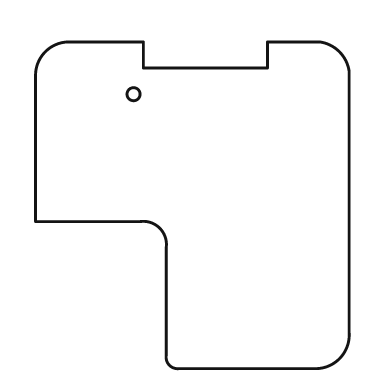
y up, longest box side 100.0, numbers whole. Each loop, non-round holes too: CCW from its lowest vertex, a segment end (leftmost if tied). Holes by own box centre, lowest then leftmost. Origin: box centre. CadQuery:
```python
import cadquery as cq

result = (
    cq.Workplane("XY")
    .moveTo(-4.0, -50.0)
    .lineTo(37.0, -50.0)
    .threePointArc((45.0, -47.0), (48.0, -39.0))
    .lineTo(48.0, 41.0)
    .threePointArc((45.0, 47.0), (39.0, 50.0))
    .lineTo(23.0, 50.0)
    .lineTo(23.0, 42.0)
    .lineTo(-15.0, 42.0)
    .lineTo(-15.0, 50.0)
    .lineTo(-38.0, 50.0)
    .threePointArc((-45.0, 47.0), (-48.0, 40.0))
    .lineTo(-48.0, -5.0)
    .lineTo(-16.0, -5.0)
    .threePointArc((-10.0, -7.0), (-8.0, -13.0))
    .lineTo(-8.0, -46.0)
    .threePointArc((-7.0, -49.0), (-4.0, -50.0))
    .close()
    .moveTo(-18.0, 34.0)
    .circle(2.0)
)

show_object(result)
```